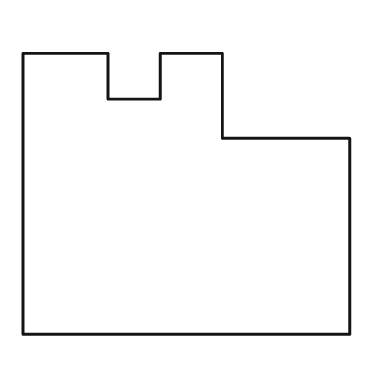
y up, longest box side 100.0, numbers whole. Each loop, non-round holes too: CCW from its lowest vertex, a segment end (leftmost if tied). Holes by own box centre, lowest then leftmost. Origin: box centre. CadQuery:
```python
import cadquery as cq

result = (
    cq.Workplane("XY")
    .moveTo(-50.0, -43.0)
    .lineTo(50.0, -43.0)
    .lineTo(50.0, 17.0)
    .lineTo(11.0, 17.0)
    .lineTo(11.0, 43.0)
    .lineTo(-8.0, 43.0)
    .lineTo(-8.0, 29.0)
    .lineTo(-24.0, 29.0)
    .lineTo(-24.0, 43.0)
    .lineTo(-50.0, 43.0)
    .close()
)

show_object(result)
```